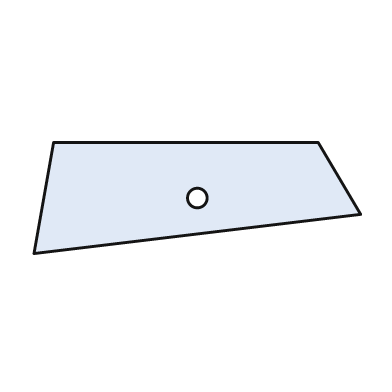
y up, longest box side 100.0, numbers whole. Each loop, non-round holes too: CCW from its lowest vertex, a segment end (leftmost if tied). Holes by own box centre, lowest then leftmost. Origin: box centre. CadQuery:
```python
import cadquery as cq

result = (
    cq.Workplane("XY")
    .moveTo(-50.0, -17.0)
    .lineTo(50.0, -5.0)
    .lineTo(37.0, 17.0)
    .lineTo(-44.0, 17.0)
    .close()
    .moveTo(0.0, 0.0)
    .circle(3.0)
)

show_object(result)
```